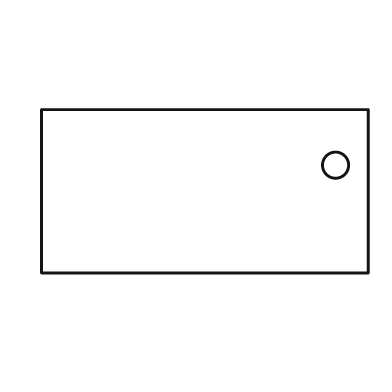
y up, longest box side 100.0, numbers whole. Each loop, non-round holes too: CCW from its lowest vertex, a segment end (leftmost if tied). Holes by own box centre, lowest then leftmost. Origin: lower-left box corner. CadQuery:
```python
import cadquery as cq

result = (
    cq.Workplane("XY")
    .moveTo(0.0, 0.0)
    .lineTo(100.0, 0.0)
    .lineTo(100.0, 50.0)
    .lineTo(0.0, 50.0)
    .close()
    .moveTo(90.0, 33.0)
    .circle(4.0)
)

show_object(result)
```